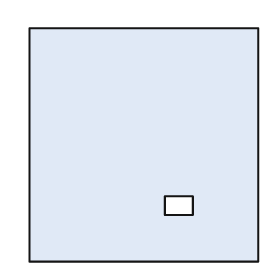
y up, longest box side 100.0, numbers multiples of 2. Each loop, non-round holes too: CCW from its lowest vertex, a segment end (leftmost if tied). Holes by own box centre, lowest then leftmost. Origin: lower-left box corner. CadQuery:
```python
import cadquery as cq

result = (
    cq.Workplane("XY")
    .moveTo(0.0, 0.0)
    .lineTo(98.0, 0.0)
    .lineTo(98.0, 100.0)
    .lineTo(0.0, 100.0)
    .close()
    .moveTo(58.0, 20.0)
    .lineTo(70.0, 20.0)
    .lineTo(70.0, 28.0)
    .lineTo(58.0, 28.0)
    .close()
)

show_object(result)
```